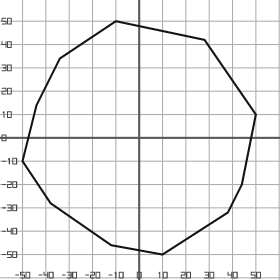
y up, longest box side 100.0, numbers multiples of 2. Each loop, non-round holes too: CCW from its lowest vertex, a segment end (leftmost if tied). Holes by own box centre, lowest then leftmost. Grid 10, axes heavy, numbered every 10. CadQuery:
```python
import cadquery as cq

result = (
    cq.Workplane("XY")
    .moveTo(10.0, -50.0)
    .lineTo(38.0, -32.0)
    .lineTo(44.0, -20.0)
    .lineTo(50.0, 10.0)
    .lineTo(28.0, 42.0)
    .lineTo(-10.0, 50.0)
    .lineTo(-34.0, 34.0)
    .lineTo(-44.0, 14.0)
    .lineTo(-50.0, -10.0)
    .lineTo(-38.0, -28.0)
    .lineTo(-12.0, -46.0)
    .close()
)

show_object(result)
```